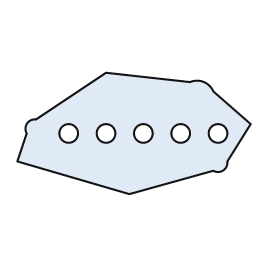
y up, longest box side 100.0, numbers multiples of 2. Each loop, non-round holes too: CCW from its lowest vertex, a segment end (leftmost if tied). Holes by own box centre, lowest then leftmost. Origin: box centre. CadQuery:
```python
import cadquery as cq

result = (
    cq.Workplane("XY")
    .moveTo(-2.0, -26.0)
    .lineTo(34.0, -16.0)
    .threePointArc((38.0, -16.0), (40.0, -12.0))
    .lineTo(50.0, 4.0)
    .lineTo(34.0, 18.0)
    .threePointArc((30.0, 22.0), (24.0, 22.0))
    .lineTo(-12.0, 26.0)
    .lineTo(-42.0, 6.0)
    .threePointArc((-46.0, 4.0), (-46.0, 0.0))
    .lineTo(-50.0, -12.0)
    .close()
    .moveTo(-28.0, 0.0)
    .circle(4.0)
    .moveTo(-12.0, 0.0)
    .circle(4.0)
    .moveTo(4.0, 0.0)
    .circle(4.0)
    .moveTo(20.0, 0.0)
    .circle(4.0)
    .moveTo(36.0, 0.0)
    .circle(4.0)
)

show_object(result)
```